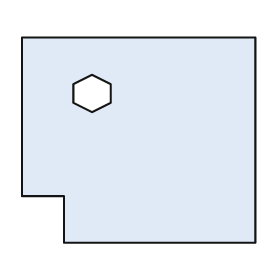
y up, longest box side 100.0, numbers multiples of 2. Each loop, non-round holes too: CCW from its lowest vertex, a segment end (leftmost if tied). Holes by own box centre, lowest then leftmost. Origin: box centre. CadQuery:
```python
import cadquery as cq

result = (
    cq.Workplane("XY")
    .moveTo(-32.0, -44.0)
    .lineTo(50.0, -44.0)
    .lineTo(50.0, 44.0)
    .lineTo(-50.0, 44.0)
    .lineTo(-50.0, -24.0)
    .lineTo(-32.0, -24.0)
    .close()
    .moveTo(-20.0, 12.0)
    .lineTo(-12.0, 16.0)
    .lineTo(-12.0, 24.0)
    .lineTo(-20.0, 28.0)
    .lineTo(-28.0, 24.0)
    .lineTo(-28.0, 16.0)
    .close()
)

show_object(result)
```